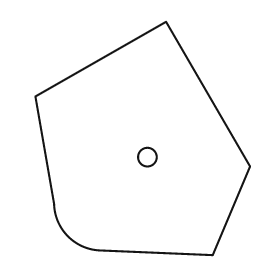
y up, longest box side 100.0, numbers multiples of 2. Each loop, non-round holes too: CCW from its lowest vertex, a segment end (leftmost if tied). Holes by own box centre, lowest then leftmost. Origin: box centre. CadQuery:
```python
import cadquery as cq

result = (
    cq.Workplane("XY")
    .moveTo(30.0, -50.0)
    .lineTo(46.0, -12.0)
    .lineTo(10.0, 50.0)
    .lineTo(-46.0, 18.0)
    .lineTo(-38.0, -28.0)
    .threePointArc((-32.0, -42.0), (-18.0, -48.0))
    .close()
    .moveTo(2.0, -8.0)
    .circle(4.0)
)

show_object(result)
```